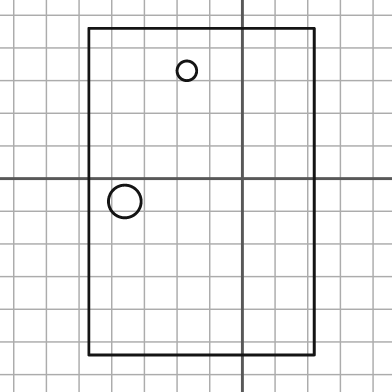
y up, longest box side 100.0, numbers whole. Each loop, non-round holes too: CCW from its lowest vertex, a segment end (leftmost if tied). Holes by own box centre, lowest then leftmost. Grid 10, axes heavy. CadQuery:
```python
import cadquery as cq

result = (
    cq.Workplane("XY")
    .moveTo(-47.0, -54.0)
    .lineTo(22.0, -54.0)
    .lineTo(22.0, 46.0)
    .lineTo(-47.0, 46.0)
    .close()
    .moveTo(-36.0, -7.0)
    .circle(5.0)
    .moveTo(-17.0, 33.0)
    .circle(3.0)
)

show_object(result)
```